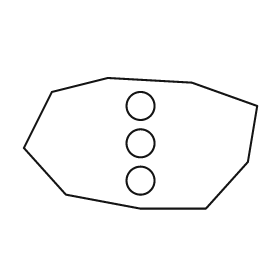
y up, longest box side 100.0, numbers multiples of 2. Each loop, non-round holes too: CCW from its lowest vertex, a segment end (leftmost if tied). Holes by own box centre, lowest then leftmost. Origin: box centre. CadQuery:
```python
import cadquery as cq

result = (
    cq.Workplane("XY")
    .moveTo(0.0, -28.0)
    .lineTo(28.0, -28.0)
    .lineTo(46.0, -8.0)
    .lineTo(50.0, 16.0)
    .lineTo(22.0, 26.0)
    .lineTo(-14.0, 28.0)
    .lineTo(-38.0, 22.0)
    .lineTo(-50.0, -2.0)
    .lineTo(-32.0, -22.0)
    .close()
    .moveTo(0.0, -16.0)
    .circle(6.0)
    .moveTo(0.0, 0.0)
    .circle(6.0)
    .moveTo(0.0, 16.0)
    .circle(6.0)
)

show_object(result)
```